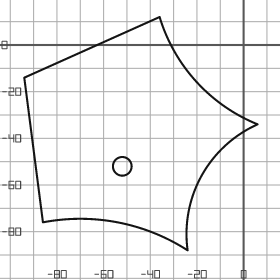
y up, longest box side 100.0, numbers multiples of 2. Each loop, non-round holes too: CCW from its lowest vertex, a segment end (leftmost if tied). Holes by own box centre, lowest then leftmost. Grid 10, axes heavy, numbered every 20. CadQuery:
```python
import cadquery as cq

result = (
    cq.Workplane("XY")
    .moveTo(-24.0, -88.0)
    .threePointArc((-18.0, -56.0), (6.0, -34.0))
    .threePointArc((-20.0, -16.0), (-36.0, 12.0))
    .lineTo(-94.0, -14.0)
    .lineTo(-86.0, -76.0)
    .threePointArc((-54.0, -76.0), (-24.0, -88.0))
    .close()
    .moveTo(-52.0, -52.0)
    .circle(4.0)
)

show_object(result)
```